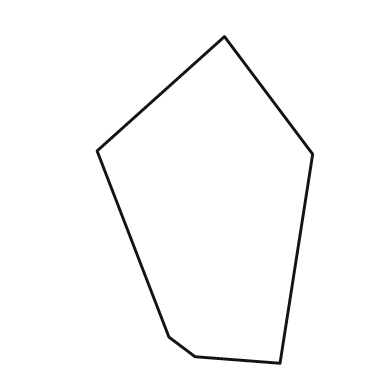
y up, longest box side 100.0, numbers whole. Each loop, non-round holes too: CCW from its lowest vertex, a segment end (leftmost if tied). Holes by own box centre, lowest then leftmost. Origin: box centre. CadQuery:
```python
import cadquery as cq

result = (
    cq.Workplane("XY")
    .moveTo(23.0, -50.0)
    .lineTo(33.0, 14.0)
    .lineTo(6.0, 50.0)
    .lineTo(-33.0, 15.0)
    .lineTo(-11.0, -42.0)
    .lineTo(-3.0, -48.0)
    .close()
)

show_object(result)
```